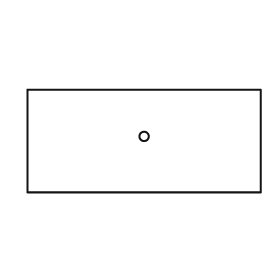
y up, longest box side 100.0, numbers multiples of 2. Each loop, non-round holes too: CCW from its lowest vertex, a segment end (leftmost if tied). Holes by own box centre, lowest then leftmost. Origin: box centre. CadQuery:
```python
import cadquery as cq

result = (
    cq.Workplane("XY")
    .moveTo(-50.0, -22.0)
    .lineTo(50.0, -22.0)
    .lineTo(50.0, 22.0)
    .lineTo(-50.0, 22.0)
    .close()
    .moveTo(0.0, 2.0)
    .circle(2.0)
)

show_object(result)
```